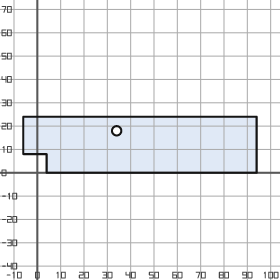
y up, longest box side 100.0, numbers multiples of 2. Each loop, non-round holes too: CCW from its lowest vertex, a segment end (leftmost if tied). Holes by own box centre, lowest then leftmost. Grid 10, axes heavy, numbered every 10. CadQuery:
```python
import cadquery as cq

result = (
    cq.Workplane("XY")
    .moveTo(4.0, 0.0)
    .lineTo(94.0, 0.0)
    .lineTo(94.0, 24.0)
    .lineTo(-6.0, 24.0)
    .lineTo(-6.0, 8.0)
    .lineTo(4.0, 8.0)
    .close()
    .moveTo(34.0, 18.0)
    .circle(2.0)
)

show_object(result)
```